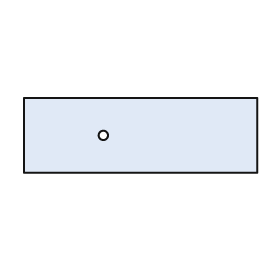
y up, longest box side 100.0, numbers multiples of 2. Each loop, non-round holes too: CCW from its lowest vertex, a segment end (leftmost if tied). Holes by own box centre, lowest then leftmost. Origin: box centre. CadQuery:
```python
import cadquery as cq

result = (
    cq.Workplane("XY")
    .moveTo(-50.0, -16.0)
    .lineTo(50.0, -16.0)
    .lineTo(50.0, 16.0)
    .lineTo(-50.0, 16.0)
    .close()
    .moveTo(-16.0, 0.0)
    .circle(2.0)
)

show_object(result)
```